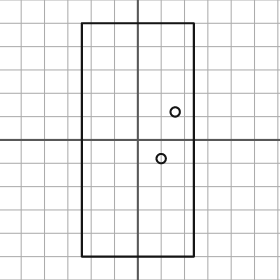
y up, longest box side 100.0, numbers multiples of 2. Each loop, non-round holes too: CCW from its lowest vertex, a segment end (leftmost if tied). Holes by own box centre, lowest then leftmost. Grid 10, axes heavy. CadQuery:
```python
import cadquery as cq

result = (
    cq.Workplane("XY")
    .moveTo(-24.0, -50.0)
    .lineTo(24.0, -50.0)
    .lineTo(24.0, 50.0)
    .lineTo(-24.0, 50.0)
    .close()
    .moveTo(10.0, -8.0)
    .circle(2.0)
    .moveTo(16.0, 12.0)
    .circle(2.0)
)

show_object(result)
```